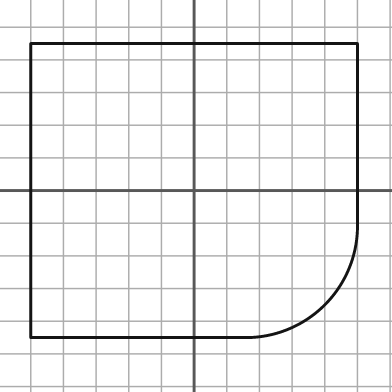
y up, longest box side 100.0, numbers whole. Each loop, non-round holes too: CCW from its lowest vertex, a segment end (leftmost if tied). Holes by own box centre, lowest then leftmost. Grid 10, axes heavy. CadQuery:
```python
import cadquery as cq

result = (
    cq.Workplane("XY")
    .moveTo(-50.0, -45.0)
    .lineTo(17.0, -45.0)
    .threePointArc((40.0, -35.0), (50.0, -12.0))
    .lineTo(50.0, 45.0)
    .lineTo(-50.0, 45.0)
    .close()
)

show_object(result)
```